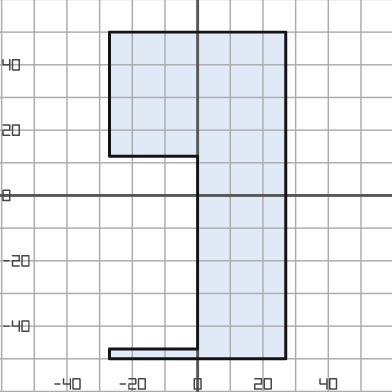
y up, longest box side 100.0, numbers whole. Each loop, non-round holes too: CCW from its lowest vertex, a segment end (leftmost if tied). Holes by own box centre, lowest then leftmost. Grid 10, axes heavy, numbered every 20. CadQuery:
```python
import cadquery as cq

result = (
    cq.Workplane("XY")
    .moveTo(-27.0, -50.0)
    .lineTo(27.0, -50.0)
    .lineTo(27.0, 50.0)
    .lineTo(-27.0, 50.0)
    .lineTo(-27.0, 12.0)
    .lineTo(0.0, 12.0)
    .lineTo(0.0, -47.0)
    .lineTo(-27.0, -47.0)
    .close()
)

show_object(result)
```